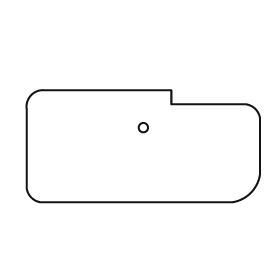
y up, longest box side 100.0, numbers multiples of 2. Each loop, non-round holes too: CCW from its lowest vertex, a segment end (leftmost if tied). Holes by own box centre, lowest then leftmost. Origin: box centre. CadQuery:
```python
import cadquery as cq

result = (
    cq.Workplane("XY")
    .moveTo(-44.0, -24.0)
    .lineTo(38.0, -24.0)
    .threePointArc((46.0, -20.0), (50.0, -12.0))
    .lineTo(50.0, 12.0)
    .threePointArc((48.0, 16.0), (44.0, 18.0))
    .lineTo(12.0, 18.0)
    .lineTo(12.0, 24.0)
    .lineTo(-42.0, 24.0)
    .threePointArc((-48.0, 22.0), (-50.0, 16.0))
    .lineTo(-50.0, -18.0)
    .threePointArc((-48.0, -22.0), (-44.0, -24.0))
    .close()
    .moveTo(0.0, 8.0)
    .circle(2.0)
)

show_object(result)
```